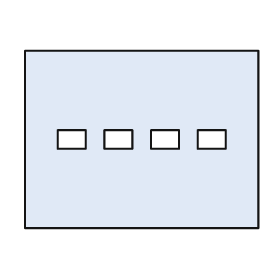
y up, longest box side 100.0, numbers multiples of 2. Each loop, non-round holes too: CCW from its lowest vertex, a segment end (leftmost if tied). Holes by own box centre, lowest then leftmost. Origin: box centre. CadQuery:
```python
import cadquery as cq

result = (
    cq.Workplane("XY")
    .moveTo(-50.0, -38.0)
    .lineTo(50.0, -38.0)
    .lineTo(50.0, 38.0)
    .lineTo(-50.0, 38.0)
    .close()
    .moveTo(-36.0, -4.0)
    .lineTo(-24.0, -4.0)
    .lineTo(-24.0, 4.0)
    .lineTo(-36.0, 4.0)
    .close()
    .moveTo(-16.0, -4.0)
    .lineTo(-4.0, -4.0)
    .lineTo(-4.0, 4.0)
    .lineTo(-16.0, 4.0)
    .close()
    .moveTo(4.0, -4.0)
    .lineTo(16.0, -4.0)
    .lineTo(16.0, 4.0)
    .lineTo(4.0, 4.0)
    .close()
    .moveTo(24.0, -4.0)
    .lineTo(36.0, -4.0)
    .lineTo(36.0, 4.0)
    .lineTo(24.0, 4.0)
    .close()
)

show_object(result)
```